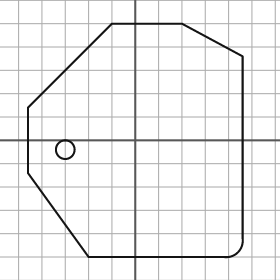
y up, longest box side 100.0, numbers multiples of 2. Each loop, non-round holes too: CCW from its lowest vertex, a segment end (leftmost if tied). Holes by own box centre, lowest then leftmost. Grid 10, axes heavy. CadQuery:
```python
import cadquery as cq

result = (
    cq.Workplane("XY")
    .moveTo(-20.0, -50.0)
    .lineTo(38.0, -50.0)
    .threePointArc((44.0, -48.0), (46.0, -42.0))
    .lineTo(46.0, 36.0)
    .lineTo(20.0, 50.0)
    .lineTo(-10.0, 50.0)
    .lineTo(-46.0, 14.0)
    .lineTo(-46.0, -14.0)
    .close()
    .moveTo(-30.0, -4.0)
    .circle(4.0)
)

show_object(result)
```